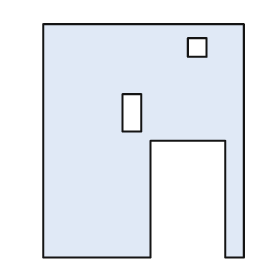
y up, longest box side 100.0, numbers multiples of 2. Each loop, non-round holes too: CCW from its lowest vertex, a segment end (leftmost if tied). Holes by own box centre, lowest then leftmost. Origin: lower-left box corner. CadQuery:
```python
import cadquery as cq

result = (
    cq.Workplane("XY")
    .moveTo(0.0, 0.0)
    .lineTo(46.0, 0.0)
    .lineTo(46.0, 50.0)
    .lineTo(78.0, 50.0)
    .lineTo(78.0, 0.0)
    .lineTo(86.0, 0.0)
    .lineTo(86.0, 100.0)
    .lineTo(0.0, 100.0)
    .close()
    .moveTo(34.0, 54.0)
    .lineTo(42.0, 54.0)
    .lineTo(42.0, 70.0)
    .lineTo(34.0, 70.0)
    .close()
    .moveTo(62.0, 86.0)
    .lineTo(70.0, 86.0)
    .lineTo(70.0, 94.0)
    .lineTo(62.0, 94.0)
    .close()
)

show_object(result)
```